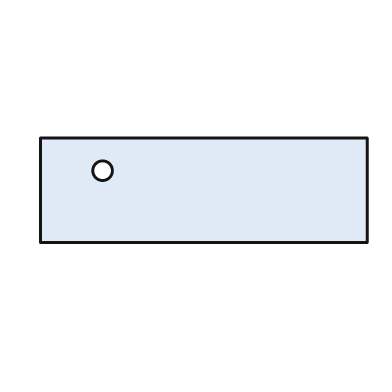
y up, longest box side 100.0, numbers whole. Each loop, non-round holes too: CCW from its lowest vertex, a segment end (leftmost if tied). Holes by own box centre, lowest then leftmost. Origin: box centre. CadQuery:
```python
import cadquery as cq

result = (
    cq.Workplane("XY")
    .moveTo(-50.0, -16.0)
    .lineTo(50.0, -16.0)
    .lineTo(50.0, 16.0)
    .lineTo(-50.0, 16.0)
    .close()
    .moveTo(-31.0, 6.0)
    .circle(3.0)
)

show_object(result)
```